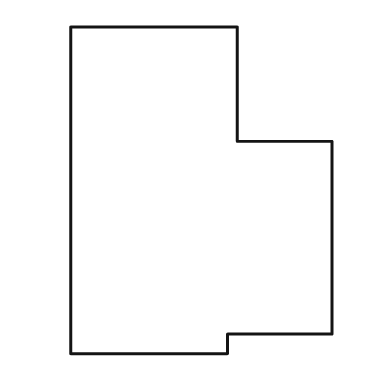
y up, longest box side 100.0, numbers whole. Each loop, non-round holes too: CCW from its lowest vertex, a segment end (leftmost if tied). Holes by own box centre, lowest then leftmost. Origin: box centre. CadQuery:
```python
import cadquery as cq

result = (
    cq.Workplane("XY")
    .moveTo(-40.0, -50.0)
    .lineTo(8.0, -50.0)
    .lineTo(8.0, -44.0)
    .lineTo(40.0, -44.0)
    .lineTo(40.0, 15.0)
    .lineTo(11.0, 15.0)
    .lineTo(11.0, 50.0)
    .lineTo(-40.0, 50.0)
    .close()
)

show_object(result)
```